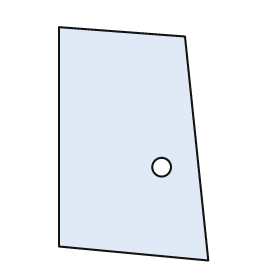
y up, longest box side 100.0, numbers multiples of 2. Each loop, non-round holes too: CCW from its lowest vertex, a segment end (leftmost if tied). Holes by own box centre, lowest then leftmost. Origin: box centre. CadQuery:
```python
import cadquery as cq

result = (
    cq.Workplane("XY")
    .moveTo(32.0, -50.0)
    .lineTo(22.0, 46.0)
    .lineTo(-32.0, 50.0)
    .lineTo(-32.0, -44.0)
    .close()
    .moveTo(12.0, -10.0)
    .circle(4.0)
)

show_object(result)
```